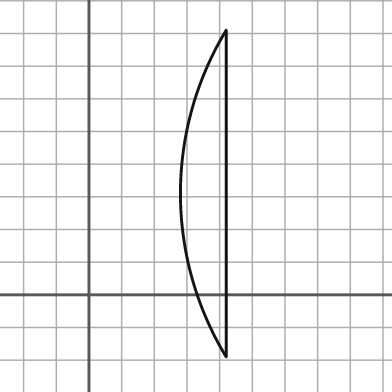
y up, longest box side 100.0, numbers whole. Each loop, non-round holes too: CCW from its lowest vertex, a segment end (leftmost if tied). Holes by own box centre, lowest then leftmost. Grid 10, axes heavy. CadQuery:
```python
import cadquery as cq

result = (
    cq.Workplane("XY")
    .moveTo(42.0, -19.0)
    .lineTo(42.0, 81.0)
    .threePointArc((28.0, 31.0), (42.0, -19.0))
    .close()
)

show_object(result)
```